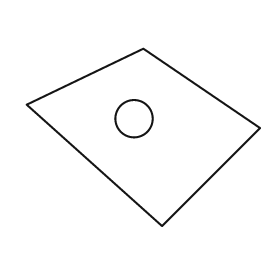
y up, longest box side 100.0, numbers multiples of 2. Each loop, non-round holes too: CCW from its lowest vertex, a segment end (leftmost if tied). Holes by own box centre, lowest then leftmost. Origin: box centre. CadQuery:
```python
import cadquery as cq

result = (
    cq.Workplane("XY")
    .moveTo(8.0, -38.0)
    .lineTo(50.0, 4.0)
    .lineTo(0.0, 38.0)
    .lineTo(-50.0, 14.0)
    .close()
    .moveTo(-4.0, 8.0)
    .circle(8.0)
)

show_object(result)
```